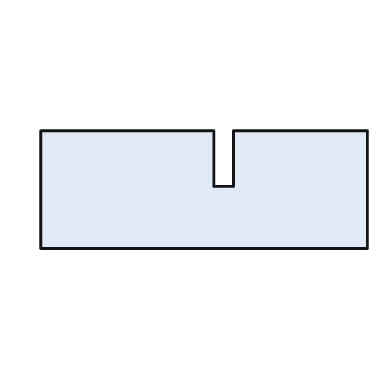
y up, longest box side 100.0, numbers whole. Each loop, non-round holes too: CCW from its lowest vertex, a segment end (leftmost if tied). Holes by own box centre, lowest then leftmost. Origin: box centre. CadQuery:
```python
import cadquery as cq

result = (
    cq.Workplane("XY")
    .moveTo(-50.0, -18.0)
    .lineTo(50.0, -18.0)
    .lineTo(50.0, 18.0)
    .lineTo(9.0, 18.0)
    .lineTo(9.0, 1.0)
    .lineTo(3.0, 1.0)
    .lineTo(3.0, 18.0)
    .lineTo(-50.0, 18.0)
    .close()
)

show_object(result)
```